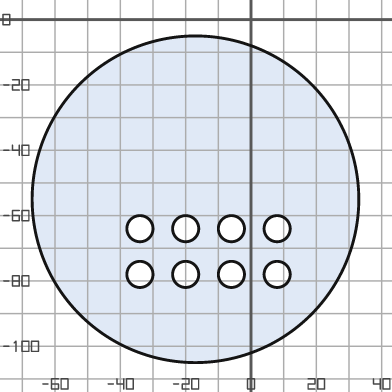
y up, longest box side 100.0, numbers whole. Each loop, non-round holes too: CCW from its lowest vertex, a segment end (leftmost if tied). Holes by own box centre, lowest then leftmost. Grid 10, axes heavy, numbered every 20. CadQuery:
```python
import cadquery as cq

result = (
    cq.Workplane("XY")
    .moveTo(-17.0, -55.0)
    .circle(50.0)
    .moveTo(-34.0, -78.0)
    .circle(4.0)
    .moveTo(-20.0, -78.0)
    .circle(4.0)
    .moveTo(-6.0, -78.0)
    .circle(4.0)
    .moveTo(8.0, -78.0)
    .circle(4.0)
    .moveTo(-34.0, -64.0)
    .circle(4.0)
    .moveTo(-20.0, -64.0)
    .circle(4.0)
    .moveTo(-6.0, -64.0)
    .circle(4.0)
    .moveTo(8.0, -64.0)
    .circle(4.0)
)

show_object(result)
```